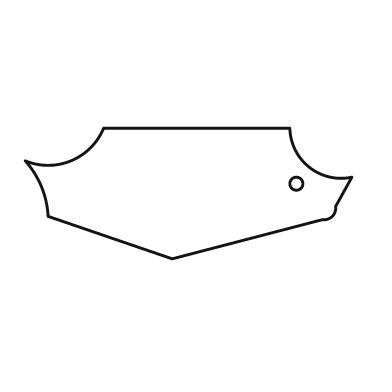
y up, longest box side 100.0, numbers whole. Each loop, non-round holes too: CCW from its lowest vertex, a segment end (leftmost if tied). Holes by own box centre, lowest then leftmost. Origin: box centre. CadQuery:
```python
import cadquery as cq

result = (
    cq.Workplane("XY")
    .moveTo(-5.0, -20.0)
    .lineTo(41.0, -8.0)
    .threePointArc((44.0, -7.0), (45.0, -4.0))
    .lineTo(50.0, 5.0)
    .threePointArc((37.0, 8.0), (31.0, 20.0))
    .lineTo(-26.0, 20.0)
    .threePointArc((-36.0, 10.0), (-50.0, 10.0))
    .threePointArc((-45.0, 2.0), (-43.0, -7.0))
    .close()
    .moveTo(33.0, 3.0)
    .circle(2.0)
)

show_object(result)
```